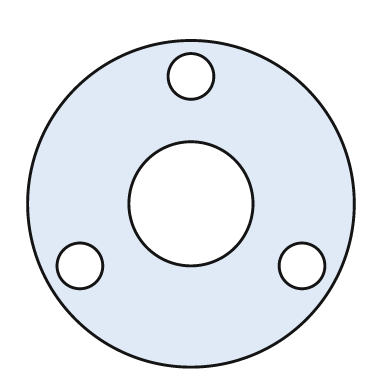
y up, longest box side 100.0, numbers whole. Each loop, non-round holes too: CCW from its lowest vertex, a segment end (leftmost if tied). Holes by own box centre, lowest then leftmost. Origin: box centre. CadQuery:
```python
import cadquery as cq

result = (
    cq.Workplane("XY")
    .moveTo(0.0, 0.0)
    .circle(50.0)
    .moveTo(-34.0, -19.0)
    .circle(7.0)
    .moveTo(34.0, -19.0)
    .circle(7.0)
    .moveTo(0.0, 0.0)
    .circle(19.0)
    .moveTo(0.0, 39.0)
    .circle(7.0)
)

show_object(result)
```